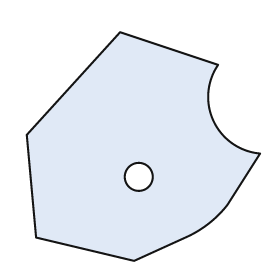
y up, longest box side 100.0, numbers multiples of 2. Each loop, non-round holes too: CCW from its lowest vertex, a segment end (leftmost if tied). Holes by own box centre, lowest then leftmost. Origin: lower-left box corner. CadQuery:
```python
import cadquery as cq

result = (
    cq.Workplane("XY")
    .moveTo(46.0, 0.0)
    .lineTo(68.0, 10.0)
    .threePointArc((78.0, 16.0), (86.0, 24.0))
    .lineTo(100.0, 46.0)
    .threePointArc((80.0, 60.0), (82.0, 84.0))
    .lineTo(40.0, 98.0)
    .lineTo(0.0, 54.0)
    .lineTo(4.0, 10.0)
    .close()
    .moveTo(48.0, 36.0)
    .circle(6.0)
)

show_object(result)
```